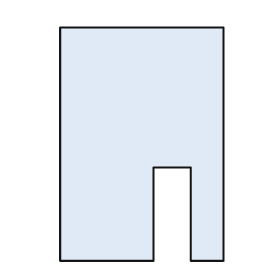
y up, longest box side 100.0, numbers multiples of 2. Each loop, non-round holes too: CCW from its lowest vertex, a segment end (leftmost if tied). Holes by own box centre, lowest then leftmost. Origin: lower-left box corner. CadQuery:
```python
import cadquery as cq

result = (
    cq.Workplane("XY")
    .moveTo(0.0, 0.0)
    .lineTo(40.0, 0.0)
    .lineTo(40.0, 40.0)
    .lineTo(56.0, 40.0)
    .lineTo(56.0, 0.0)
    .lineTo(70.0, 0.0)
    .lineTo(70.0, 100.0)
    .lineTo(0.0, 100.0)
    .close()
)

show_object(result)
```